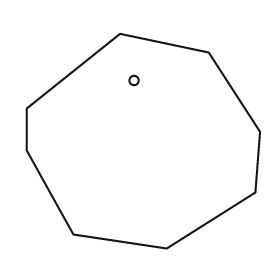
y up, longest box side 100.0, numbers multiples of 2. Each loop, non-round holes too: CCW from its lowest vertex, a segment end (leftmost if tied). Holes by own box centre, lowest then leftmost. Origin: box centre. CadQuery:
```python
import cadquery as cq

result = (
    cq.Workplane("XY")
    .moveTo(10.0, -46.0)
    .lineTo(48.0, -22.0)
    .lineTo(50.0, 4.0)
    .lineTo(28.0, 38.0)
    .lineTo(-10.0, 46.0)
    .lineTo(-50.0, 14.0)
    .lineTo(-50.0, -4.0)
    .lineTo(-30.0, -40.0)
    .close()
    .moveTo(-4.0, 26.0)
    .circle(2.0)
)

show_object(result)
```